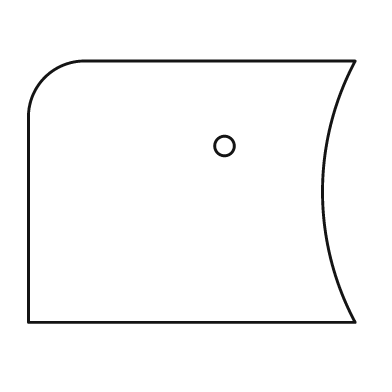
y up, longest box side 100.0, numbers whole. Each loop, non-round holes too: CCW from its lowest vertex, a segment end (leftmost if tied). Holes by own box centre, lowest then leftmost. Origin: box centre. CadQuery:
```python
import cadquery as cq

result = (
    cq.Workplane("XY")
    .moveTo(-50.0, -40.0)
    .lineTo(50.0, -40.0)
    .threePointArc((40.0, 0.0), (50.0, 40.0))
    .lineTo(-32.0, 40.0)
    .threePointArc((-45.0, 35.0), (-50.0, 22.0))
    .close()
    .moveTo(10.0, 14.0)
    .circle(3.0)
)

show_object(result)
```